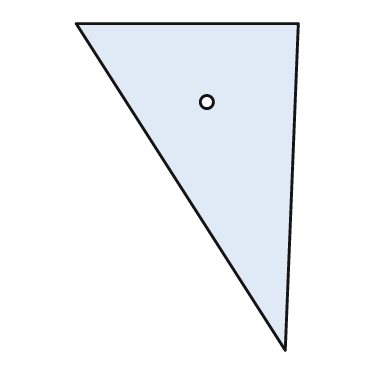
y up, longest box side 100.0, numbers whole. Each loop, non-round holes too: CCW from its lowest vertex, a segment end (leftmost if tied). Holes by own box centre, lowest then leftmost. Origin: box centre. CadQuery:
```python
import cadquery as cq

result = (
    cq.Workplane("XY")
    .moveTo(30.0, -50.0)
    .lineTo(34.0, 50.0)
    .lineTo(-34.0, 50.0)
    .close()
    .moveTo(6.0, 26.0)
    .circle(2.0)
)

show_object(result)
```